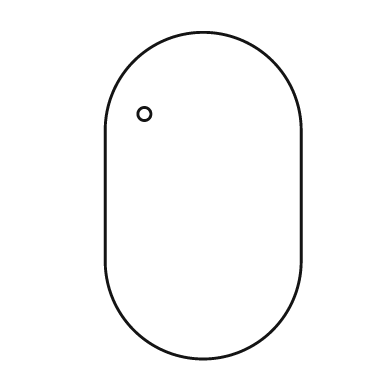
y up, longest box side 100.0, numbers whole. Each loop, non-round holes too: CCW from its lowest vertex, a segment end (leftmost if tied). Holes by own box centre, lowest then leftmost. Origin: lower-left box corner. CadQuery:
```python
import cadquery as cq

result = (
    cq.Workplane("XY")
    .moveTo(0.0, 30.0)
    .threePointArc((30.0, 0.0), (60.0, 30.0))
    .lineTo(60.0, 70.0)
    .threePointArc((30.0, 100.0), (0.0, 70.0))
    .close()
    .moveTo(12.0, 75.0)
    .circle(2.0)
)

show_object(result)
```